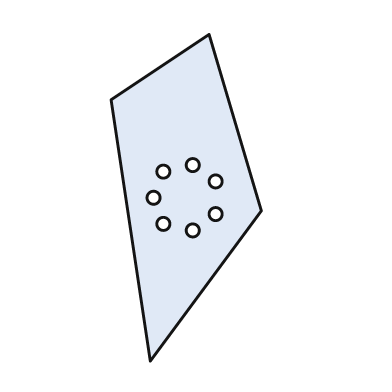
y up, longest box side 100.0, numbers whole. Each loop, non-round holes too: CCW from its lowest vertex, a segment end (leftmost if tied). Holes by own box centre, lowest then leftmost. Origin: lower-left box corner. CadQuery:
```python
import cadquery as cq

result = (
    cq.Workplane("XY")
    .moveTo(12.0, 0.0)
    .lineTo(46.0, 46.0)
    .lineTo(30.0, 100.0)
    .lineTo(0.0, 80.0)
    .close()
    .moveTo(25.0, 40.0)
    .circle(2.0)
    .moveTo(16.0, 42.0)
    .circle(2.0)
    .moveTo(32.0, 45.0)
    .circle(2.0)
    .moveTo(13.0, 50.0)
    .circle(2.0)
    .moveTo(32.0, 55.0)
    .circle(2.0)
    .moveTo(16.0, 58.0)
    .circle(2.0)
    .moveTo(25.0, 60.0)
    .circle(2.0)
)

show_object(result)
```